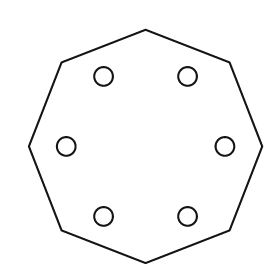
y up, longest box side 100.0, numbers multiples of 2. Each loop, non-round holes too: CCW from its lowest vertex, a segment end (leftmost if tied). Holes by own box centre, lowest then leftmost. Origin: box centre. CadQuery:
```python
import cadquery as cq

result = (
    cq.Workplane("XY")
    .moveTo(0.0, -50.0)
    .lineTo(36.0, -36.0)
    .lineTo(50.0, 0.0)
    .lineTo(36.0, 36.0)
    .lineTo(0.0, 50.0)
    .lineTo(-36.0, 36.0)
    .lineTo(-50.0, 0.0)
    .lineTo(-36.0, -36.0)
    .close()
    .moveTo(-18.0, -30.0)
    .circle(4.0)
    .moveTo(18.0, -30.0)
    .circle(4.0)
    .moveTo(-34.0, 0.0)
    .circle(4.0)
    .moveTo(34.0, 0.0)
    .circle(4.0)
    .moveTo(-18.0, 30.0)
    .circle(4.0)
    .moveTo(18.0, 30.0)
    .circle(4.0)
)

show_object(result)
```